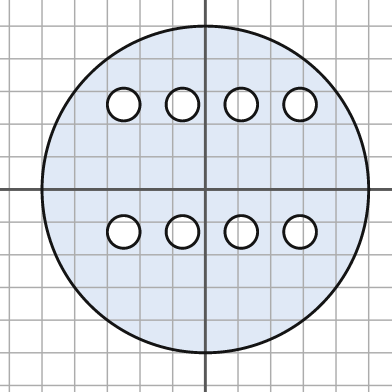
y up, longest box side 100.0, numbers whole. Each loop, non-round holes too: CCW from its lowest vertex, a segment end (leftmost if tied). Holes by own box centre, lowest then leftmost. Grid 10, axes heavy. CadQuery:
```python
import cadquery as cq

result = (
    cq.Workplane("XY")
    .moveTo(0.0, 0.0)
    .circle(50.0)
    .moveTo(-25.0, -13.0)
    .circle(5.0)
    .moveTo(-7.0, -13.0)
    .circle(5.0)
    .moveTo(11.0, -13.0)
    .circle(5.0)
    .moveTo(29.0, -13.0)
    .circle(5.0)
    .moveTo(-25.0, 26.0)
    .circle(5.0)
    .moveTo(-7.0, 26.0)
    .circle(5.0)
    .moveTo(11.0, 26.0)
    .circle(5.0)
    .moveTo(29.0, 26.0)
    .circle(5.0)
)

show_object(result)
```